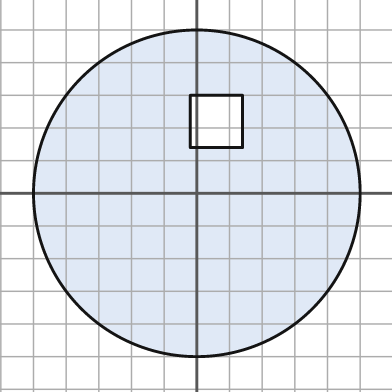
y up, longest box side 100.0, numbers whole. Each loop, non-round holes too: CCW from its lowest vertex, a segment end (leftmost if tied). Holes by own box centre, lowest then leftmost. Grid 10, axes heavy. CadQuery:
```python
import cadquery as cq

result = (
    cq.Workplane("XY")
    .moveTo(0.0, 0.0)
    .circle(50.0)
    .moveTo(-2.0, 14.0)
    .lineTo(14.0, 14.0)
    .lineTo(14.0, 30.0)
    .lineTo(-2.0, 30.0)
    .close()
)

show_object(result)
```